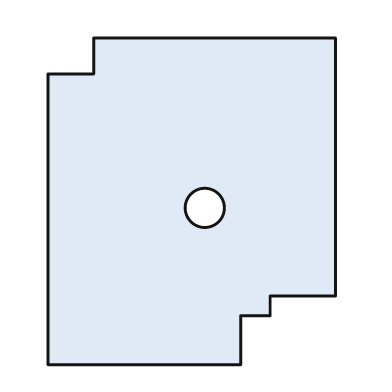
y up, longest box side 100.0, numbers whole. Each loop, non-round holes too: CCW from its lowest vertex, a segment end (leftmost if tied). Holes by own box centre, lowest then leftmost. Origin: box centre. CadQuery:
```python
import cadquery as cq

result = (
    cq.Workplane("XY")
    .moveTo(-44.0, -50.0)
    .lineTo(15.0, -50.0)
    .lineTo(15.0, -35.0)
    .lineTo(24.0, -35.0)
    .lineTo(24.0, -29.0)
    .lineTo(44.0, -29.0)
    .lineTo(44.0, 50.0)
    .lineTo(-30.0, 50.0)
    .lineTo(-30.0, 39.0)
    .lineTo(-44.0, 39.0)
    .close()
    .moveTo(4.0, -2.0)
    .circle(6.0)
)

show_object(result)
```